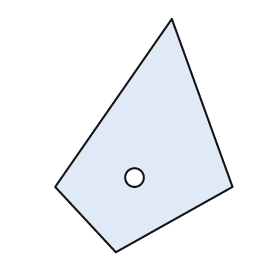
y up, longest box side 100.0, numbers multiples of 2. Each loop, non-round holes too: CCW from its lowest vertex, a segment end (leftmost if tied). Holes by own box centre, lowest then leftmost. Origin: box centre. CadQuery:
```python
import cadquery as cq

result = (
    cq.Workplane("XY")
    .moveTo(-12.0, -50.0)
    .lineTo(38.0, -22.0)
    .lineTo(12.0, 50.0)
    .lineTo(-38.0, -22.0)
    .close()
    .moveTo(-4.0, -18.0)
    .circle(4.0)
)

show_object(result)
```